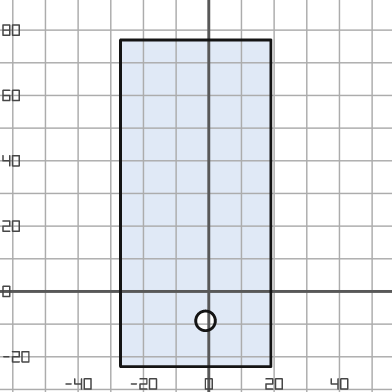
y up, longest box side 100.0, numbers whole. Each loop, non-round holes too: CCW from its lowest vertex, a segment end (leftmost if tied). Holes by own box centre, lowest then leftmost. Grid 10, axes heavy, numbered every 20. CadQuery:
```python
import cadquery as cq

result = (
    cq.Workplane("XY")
    .moveTo(-27.0, -23.0)
    .lineTo(19.0, -23.0)
    .lineTo(19.0, 77.0)
    .lineTo(-27.0, 77.0)
    .close()
    .moveTo(-1.0, -9.0)
    .circle(3.0)
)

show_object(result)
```